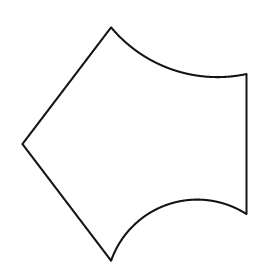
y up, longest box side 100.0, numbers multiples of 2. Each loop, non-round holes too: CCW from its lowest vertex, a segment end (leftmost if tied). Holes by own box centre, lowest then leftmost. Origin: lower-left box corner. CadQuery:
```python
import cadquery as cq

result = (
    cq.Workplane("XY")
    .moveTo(38.0, 0.0)
    .threePointArc((62.0, 24.0), (96.0, 20.0))
    .lineTo(96.0, 80.0)
    .threePointArc((64.0, 82.0), (38.0, 100.0))
    .lineTo(0.0, 50.0)
    .close()
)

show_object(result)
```